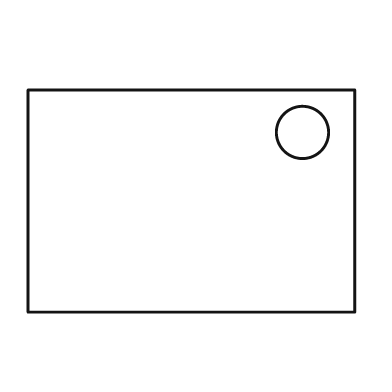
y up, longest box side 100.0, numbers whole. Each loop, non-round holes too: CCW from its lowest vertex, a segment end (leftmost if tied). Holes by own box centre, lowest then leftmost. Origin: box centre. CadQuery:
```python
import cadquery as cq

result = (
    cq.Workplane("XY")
    .moveTo(-50.0, -34.0)
    .lineTo(50.0, -34.0)
    .lineTo(50.0, 34.0)
    .lineTo(-50.0, 34.0)
    .close()
    .moveTo(34.0, 21.0)
    .circle(8.0)
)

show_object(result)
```